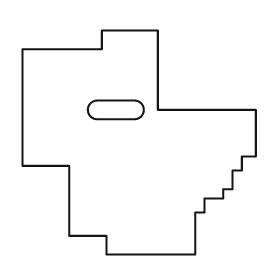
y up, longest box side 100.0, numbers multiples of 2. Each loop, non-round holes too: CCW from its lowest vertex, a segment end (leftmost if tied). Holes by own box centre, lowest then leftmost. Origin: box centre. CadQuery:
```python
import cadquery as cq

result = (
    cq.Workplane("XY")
    .moveTo(-14.0, -48.0)
    .lineTo(24.0, -48.0)
    .lineTo(24.0, -30.0)
    .lineTo(28.0, -30.0)
    .lineTo(28.0, -24.0)
    .lineTo(36.0, -24.0)
    .lineTo(36.0, -20.0)
    .lineTo(40.0, -20.0)
    .lineTo(40.0, -12.0)
    .lineTo(44.0, -12.0)
    .lineTo(44.0, -6.0)
    .lineTo(50.0, -6.0)
    .lineTo(50.0, 14.0)
    .lineTo(8.0, 14.0)
    .lineTo(8.0, 48.0)
    .lineTo(-16.0, 48.0)
    .lineTo(-16.0, 40.0)
    .lineTo(-50.0, 40.0)
    .lineTo(-50.0, -10.0)
    .lineTo(-30.0, -10.0)
    .lineTo(-30.0, -40.0)
    .lineTo(-14.0, -40.0)
    .close()
    .moveTo(-18.0, 10.0)
    .lineTo(-2.0, 10.0)
    .threePointArc((2.0, 14.0), (-2.0, 18.0))
    .lineTo(-18.0, 18.0)
    .threePointArc((-22.0, 14.0), (-18.0, 10.0))
    .close()
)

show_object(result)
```